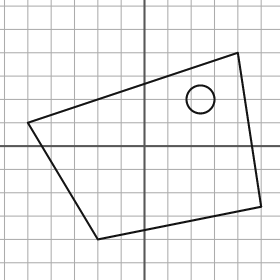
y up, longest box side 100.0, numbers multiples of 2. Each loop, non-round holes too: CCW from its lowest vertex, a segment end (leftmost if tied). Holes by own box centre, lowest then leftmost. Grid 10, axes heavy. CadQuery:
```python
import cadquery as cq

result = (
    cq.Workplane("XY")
    .moveTo(-20.0, -40.0)
    .lineTo(50.0, -26.0)
    .lineTo(40.0, 40.0)
    .lineTo(-50.0, 10.0)
    .close()
    .moveTo(24.0, 20.0)
    .circle(6.0)
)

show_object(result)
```